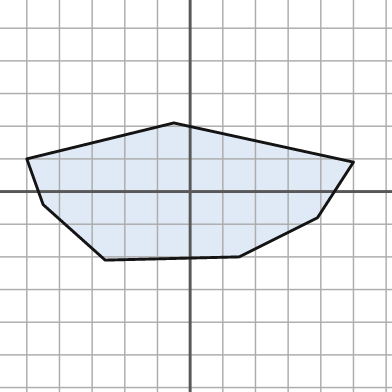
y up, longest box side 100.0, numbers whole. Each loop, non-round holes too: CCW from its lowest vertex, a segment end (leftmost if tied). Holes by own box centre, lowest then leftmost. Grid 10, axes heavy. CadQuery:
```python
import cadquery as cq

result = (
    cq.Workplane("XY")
    .moveTo(-26.0, -21.0)
    .lineTo(15.0, -20.0)
    .lineTo(39.0, -8.0)
    .lineTo(50.0, 9.0)
    .lineTo(-5.0, 21.0)
    .lineTo(-50.0, 10.0)
    .lineTo(-45.0, -4.0)
    .close()
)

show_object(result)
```